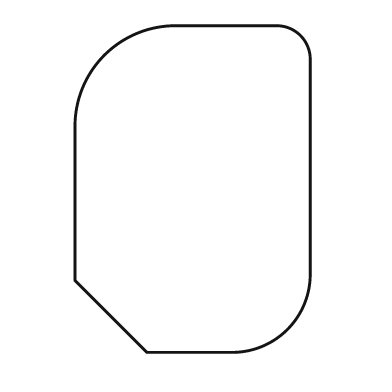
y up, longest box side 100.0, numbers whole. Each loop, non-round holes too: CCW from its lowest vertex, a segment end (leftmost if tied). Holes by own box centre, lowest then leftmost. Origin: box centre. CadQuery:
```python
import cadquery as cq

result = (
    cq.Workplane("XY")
    .moveTo(-14.0, -50.0)
    .lineTo(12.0, -50.0)
    .threePointArc((29.0, -43.0), (36.0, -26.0))
    .lineTo(36.0, 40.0)
    .threePointArc((33.0, 47.0), (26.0, 50.0))
    .lineTo(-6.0, 50.0)
    .threePointArc((-27.0, 41.0), (-36.0, 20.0))
    .lineTo(-36.0, -28.0)
    .close()
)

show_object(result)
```